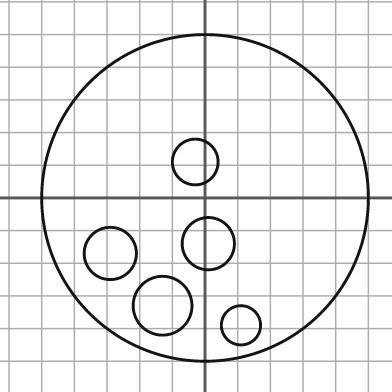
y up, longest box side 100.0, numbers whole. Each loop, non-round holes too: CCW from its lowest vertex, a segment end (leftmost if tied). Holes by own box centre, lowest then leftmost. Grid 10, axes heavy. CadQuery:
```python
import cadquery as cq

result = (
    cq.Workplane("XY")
    .moveTo(0.0, 0.0)
    .circle(50.0)
    .moveTo(11.0, -39.0)
    .circle(6.0)
    .moveTo(-13.0, -33.0)
    .circle(9.0)
    .moveTo(-29.0, -17.0)
    .circle(8.0)
    .moveTo(1.0, -14.0)
    .circle(8.0)
    .moveTo(-3.0, 11.0)
    .circle(7.0)
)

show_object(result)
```